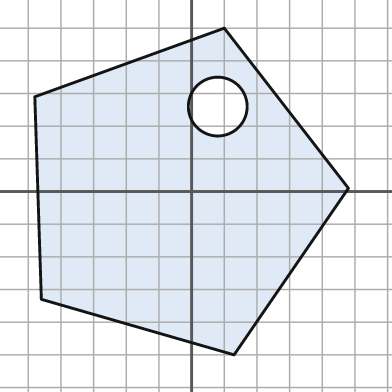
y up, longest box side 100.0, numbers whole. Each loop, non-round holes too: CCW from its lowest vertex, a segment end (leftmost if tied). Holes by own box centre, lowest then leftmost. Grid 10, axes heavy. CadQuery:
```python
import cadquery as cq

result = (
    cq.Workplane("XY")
    .moveTo(13.0, -50.0)
    .lineTo(48.0, 1.0)
    .lineTo(10.0, 50.0)
    .lineTo(-48.0, 29.0)
    .lineTo(-46.0, -33.0)
    .close()
    .moveTo(8.0, 26.0)
    .circle(9.0)
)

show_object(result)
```